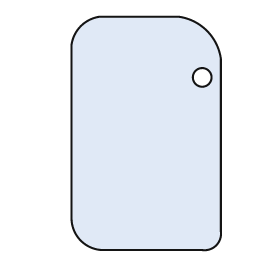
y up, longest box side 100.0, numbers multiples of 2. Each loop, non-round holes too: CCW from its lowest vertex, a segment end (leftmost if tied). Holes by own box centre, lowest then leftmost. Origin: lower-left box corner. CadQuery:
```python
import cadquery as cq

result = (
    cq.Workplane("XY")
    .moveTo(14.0, 0.0)
    .lineTo(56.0, 0.0)
    .threePointArc((62.0, 2.0), (64.0, 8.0))
    .lineTo(64.0, 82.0)
    .threePointArc((58.0, 94.0), (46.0, 100.0))
    .lineTo(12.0, 100.0)
    .threePointArc((4.0, 96.0), (0.0, 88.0))
    .lineTo(0.0, 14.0)
    .threePointArc((4.0, 4.0), (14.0, 0.0))
    .close()
    .moveTo(56.0, 74.0)
    .circle(4.0)
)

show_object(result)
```